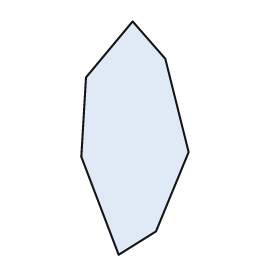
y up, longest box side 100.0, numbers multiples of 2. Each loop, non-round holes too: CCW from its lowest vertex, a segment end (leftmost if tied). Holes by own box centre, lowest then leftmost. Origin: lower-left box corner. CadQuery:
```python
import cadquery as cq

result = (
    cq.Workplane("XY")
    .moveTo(16.0, 0.0)
    .lineTo(32.0, 10.0)
    .lineTo(46.0, 44.0)
    .lineTo(36.0, 84.0)
    .lineTo(22.0, 100.0)
    .lineTo(2.0, 76.0)
    .lineTo(0.0, 42.0)
    .close()
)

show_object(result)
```